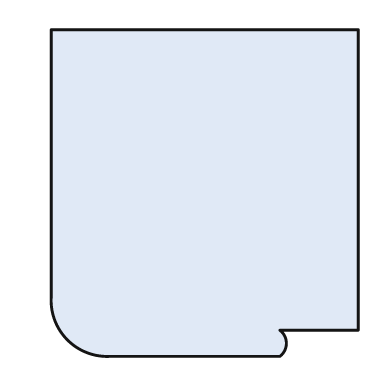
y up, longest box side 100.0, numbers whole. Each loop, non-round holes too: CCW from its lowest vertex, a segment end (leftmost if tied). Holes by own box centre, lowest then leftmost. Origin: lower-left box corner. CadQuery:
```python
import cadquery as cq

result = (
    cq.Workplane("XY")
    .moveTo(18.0, 0.0)
    .lineTo(70.0, 0.0)
    .threePointArc((72.0, 4.0), (70.0, 8.0))
    .lineTo(94.0, 8.0)
    .lineTo(94.0, 100.0)
    .lineTo(0.0, 100.0)
    .lineTo(0.0, 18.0)
    .threePointArc((5.0, 5.0), (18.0, 0.0))
    .close()
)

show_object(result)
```